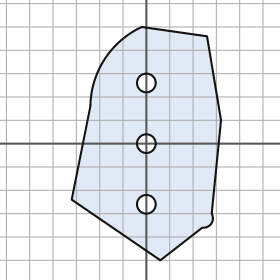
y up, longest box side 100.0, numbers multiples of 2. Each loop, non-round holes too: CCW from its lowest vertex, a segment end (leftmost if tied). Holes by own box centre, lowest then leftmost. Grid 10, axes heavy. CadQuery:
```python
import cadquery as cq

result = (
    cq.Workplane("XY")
    .moveTo(6.0, -50.0)
    .lineTo(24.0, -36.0)
    .threePointArc((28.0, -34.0), (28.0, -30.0))
    .lineTo(32.0, 10.0)
    .lineTo(26.0, 46.0)
    .lineTo(-2.0, 50.0)
    .threePointArc((-18.0, 36.0), (-24.0, 16.0))
    .lineTo(-32.0, -24.0)
    .close()
    .moveTo(0.0, -26.0)
    .circle(4.0)
    .moveTo(0.0, 0.0)
    .circle(4.0)
    .moveTo(0.0, 26.0)
    .circle(4.0)
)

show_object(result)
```